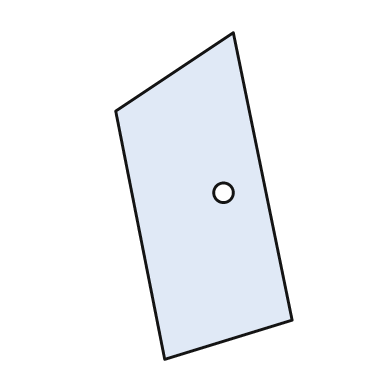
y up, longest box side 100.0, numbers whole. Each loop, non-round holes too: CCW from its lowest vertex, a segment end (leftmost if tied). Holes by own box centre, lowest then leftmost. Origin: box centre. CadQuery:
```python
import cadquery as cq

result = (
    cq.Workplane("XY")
    .moveTo(-12.0, -50.0)
    .lineTo(27.0, -38.0)
    .lineTo(9.0, 50.0)
    .lineTo(-27.0, 26.0)
    .close()
    .moveTo(6.0, 1.0)
    .circle(3.0)
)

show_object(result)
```